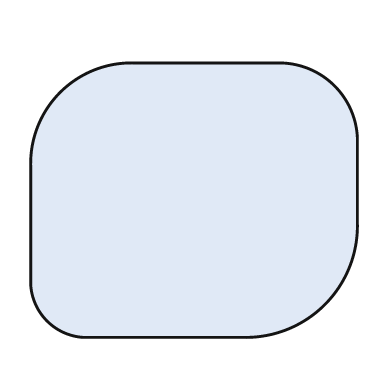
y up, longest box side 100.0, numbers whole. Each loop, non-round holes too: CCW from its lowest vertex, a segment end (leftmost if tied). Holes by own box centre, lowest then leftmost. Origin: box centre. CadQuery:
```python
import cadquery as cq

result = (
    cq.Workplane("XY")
    .moveTo(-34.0, -42.0)
    .lineTo(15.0, -42.0)
    .threePointArc((40.0, -32.0), (50.0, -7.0))
    .lineTo(50.0, 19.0)
    .threePointArc((43.0, 35.0), (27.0, 42.0))
    .lineTo(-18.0, 42.0)
    .threePointArc((-41.0, 33.0), (-50.0, 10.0))
    .lineTo(-50.0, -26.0)
    .threePointArc((-45.0, -37.0), (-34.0, -42.0))
    .close()
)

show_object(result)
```